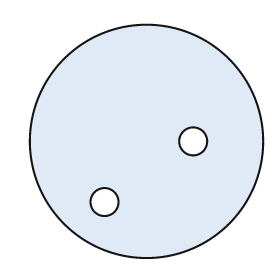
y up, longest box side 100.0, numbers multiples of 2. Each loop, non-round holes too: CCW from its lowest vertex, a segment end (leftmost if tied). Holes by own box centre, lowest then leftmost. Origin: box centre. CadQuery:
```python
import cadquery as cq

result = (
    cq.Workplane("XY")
    .moveTo(0.0, 0.0)
    .circle(50.0)
    .moveTo(-18.0, -26.0)
    .circle(6.0)
    .moveTo(20.0, 0.0)
    .circle(6.0)
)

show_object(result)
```